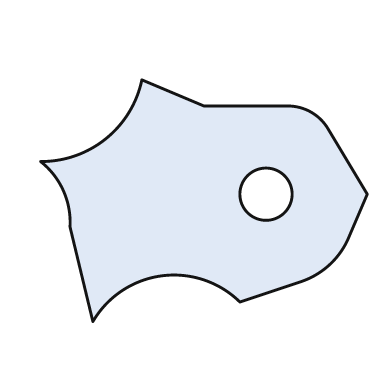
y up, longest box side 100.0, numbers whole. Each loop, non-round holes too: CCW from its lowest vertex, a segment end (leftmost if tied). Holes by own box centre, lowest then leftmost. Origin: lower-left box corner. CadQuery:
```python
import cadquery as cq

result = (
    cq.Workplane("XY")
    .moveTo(16.0, 0.0)
    .threePointArc((37.0, 14.0), (61.0, 6.0))
    .lineTo(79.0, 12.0)
    .threePointArc((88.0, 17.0), (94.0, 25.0))
    .lineTo(100.0, 39.0)
    .lineTo(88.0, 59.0)
    .threePointArc((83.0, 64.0), (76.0, 66.0))
    .lineTo(50.0, 66.0)
    .lineTo(31.0, 74.0)
    .threePointArc((20.0, 56.0), (0.0, 49.0))
    .threePointArc((7.0, 40.0), (9.0, 29.0))
    .close()
    .moveTo(69.0, 39.0)
    .circle(8.0)
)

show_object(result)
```